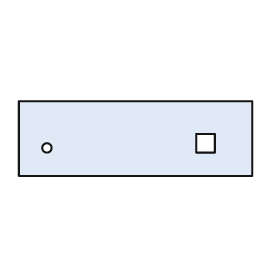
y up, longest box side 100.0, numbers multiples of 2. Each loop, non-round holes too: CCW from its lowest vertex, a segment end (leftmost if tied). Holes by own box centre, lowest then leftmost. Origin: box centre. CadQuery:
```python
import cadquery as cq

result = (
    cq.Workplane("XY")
    .moveTo(-50.0, -16.0)
    .lineTo(50.0, -16.0)
    .lineTo(50.0, 16.0)
    .lineTo(-50.0, 16.0)
    .close()
    .moveTo(-38.0, -4.0)
    .circle(2.0)
    .moveTo(26.0, -6.0)
    .lineTo(34.0, -6.0)
    .lineTo(34.0, 2.0)
    .lineTo(26.0, 2.0)
    .close()
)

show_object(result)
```